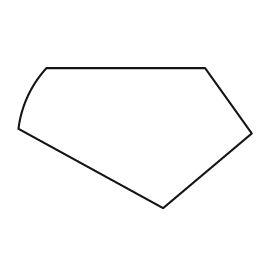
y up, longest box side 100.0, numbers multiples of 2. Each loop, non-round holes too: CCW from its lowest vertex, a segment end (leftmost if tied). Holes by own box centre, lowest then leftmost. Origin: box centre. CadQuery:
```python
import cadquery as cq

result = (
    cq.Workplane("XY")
    .moveTo(12.0, -30.0)
    .lineTo(50.0, 2.0)
    .lineTo(30.0, 30.0)
    .lineTo(-38.0, 30.0)
    .threePointArc((-46.0, 18.0), (-50.0, 4.0))
    .close()
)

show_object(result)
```